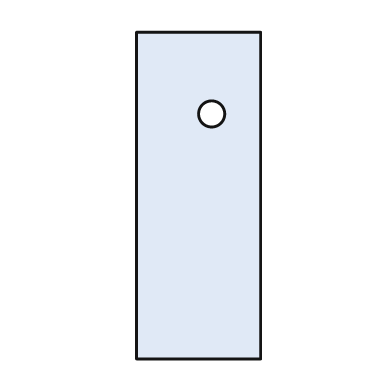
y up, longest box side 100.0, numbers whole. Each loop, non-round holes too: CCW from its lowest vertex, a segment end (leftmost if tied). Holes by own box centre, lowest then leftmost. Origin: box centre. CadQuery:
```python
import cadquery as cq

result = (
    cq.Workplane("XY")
    .moveTo(-19.0, -50.0)
    .lineTo(19.0, -50.0)
    .lineTo(19.0, 50.0)
    .lineTo(-19.0, 50.0)
    .close()
    .moveTo(4.0, 25.0)
    .circle(4.0)
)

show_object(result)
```